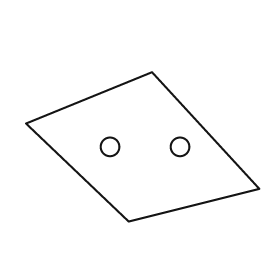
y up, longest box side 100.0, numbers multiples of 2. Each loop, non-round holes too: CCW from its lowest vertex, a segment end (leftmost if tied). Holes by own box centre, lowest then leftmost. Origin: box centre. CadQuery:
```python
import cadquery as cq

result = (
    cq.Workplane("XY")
    .moveTo(-6.0, -32.0)
    .lineTo(50.0, -18.0)
    .lineTo(4.0, 32.0)
    .lineTo(-50.0, 10.0)
    .close()
    .moveTo(-14.0, 0.0)
    .circle(4.0)
    .moveTo(16.0, 0.0)
    .circle(4.0)
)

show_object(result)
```